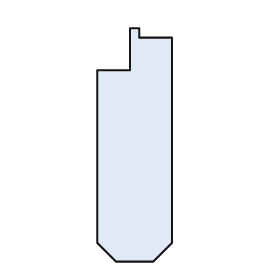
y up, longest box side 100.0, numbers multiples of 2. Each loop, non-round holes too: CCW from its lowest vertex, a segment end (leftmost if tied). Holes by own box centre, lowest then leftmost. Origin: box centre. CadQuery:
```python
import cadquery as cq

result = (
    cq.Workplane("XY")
    .moveTo(-8.0, -50.0)
    .lineTo(8.0, -50.0)
    .lineTo(16.0, -42.0)
    .lineTo(16.0, 46.0)
    .lineTo(2.0, 46.0)
    .lineTo(2.0, 50.0)
    .lineTo(-2.0, 50.0)
    .lineTo(-2.0, 32.0)
    .lineTo(-16.0, 32.0)
    .lineTo(-16.0, -42.0)
    .close()
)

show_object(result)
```